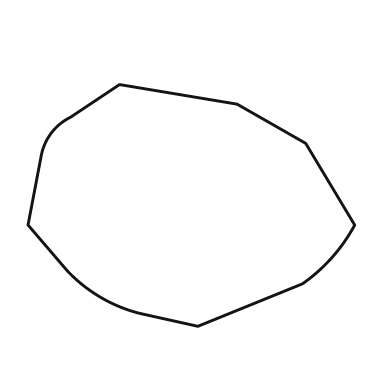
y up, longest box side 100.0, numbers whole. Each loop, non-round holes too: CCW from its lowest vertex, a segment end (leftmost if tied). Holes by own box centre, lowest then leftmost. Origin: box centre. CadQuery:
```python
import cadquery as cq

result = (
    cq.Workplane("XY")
    .moveTo(2.0, -37.0)
    .lineTo(34.0, -24.0)
    .threePointArc((43.0, -16.0), (50.0, -6.0))
    .lineTo(35.0, 19.0)
    .lineTo(14.0, 31.0)
    .lineTo(-22.0, 37.0)
    .lineTo(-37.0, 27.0)
    .threePointArc((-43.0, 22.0), (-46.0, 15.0))
    .lineTo(-50.0, -6.0)
    .lineTo(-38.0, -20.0)
    .threePointArc((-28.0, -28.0), (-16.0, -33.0))
    .close()
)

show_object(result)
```